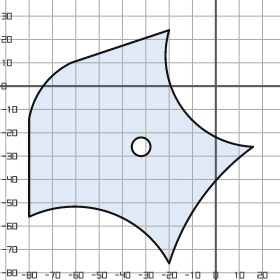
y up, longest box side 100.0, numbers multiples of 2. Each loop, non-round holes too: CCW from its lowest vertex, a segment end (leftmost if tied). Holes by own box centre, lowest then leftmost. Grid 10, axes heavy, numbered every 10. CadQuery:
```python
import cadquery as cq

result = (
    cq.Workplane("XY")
    .moveTo(-20.0, -76.0)
    .threePointArc((-6.0, -48.0), (16.0, -26.0))
    .threePointArc((-14.0, -10.0), (-20.0, 24.0))
    .lineTo(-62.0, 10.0)
    .threePointArc((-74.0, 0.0), (-80.0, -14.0))
    .lineTo(-80.0, -56.0)
    .threePointArc((-46.0, -54.0), (-20.0, -76.0))
    .close()
    .moveTo(-32.0, -26.0)
    .circle(4.0)
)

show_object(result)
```